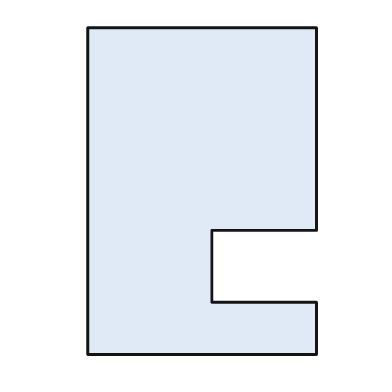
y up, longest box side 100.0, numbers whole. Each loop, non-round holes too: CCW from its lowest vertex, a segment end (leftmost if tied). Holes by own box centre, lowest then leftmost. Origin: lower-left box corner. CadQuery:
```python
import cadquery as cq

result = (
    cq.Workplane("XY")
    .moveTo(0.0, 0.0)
    .lineTo(70.0, 0.0)
    .lineTo(70.0, 16.0)
    .lineTo(38.0, 16.0)
    .lineTo(38.0, 38.0)
    .lineTo(70.0, 38.0)
    .lineTo(70.0, 100.0)
    .lineTo(0.0, 100.0)
    .close()
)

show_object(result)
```